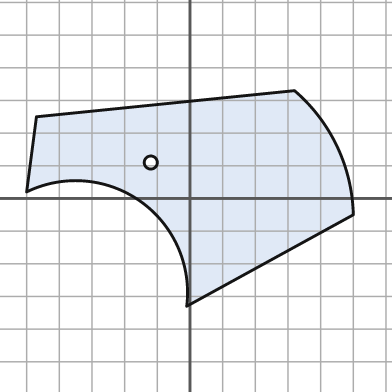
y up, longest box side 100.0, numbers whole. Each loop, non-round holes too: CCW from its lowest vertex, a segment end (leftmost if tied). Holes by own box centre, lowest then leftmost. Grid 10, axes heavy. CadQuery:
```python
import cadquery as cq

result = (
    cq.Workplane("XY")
    .moveTo(-1.0, -33.0)
    .lineTo(50.0, -5.0)
    .threePointArc((45.0, 16.0), (32.0, 33.0))
    .lineTo(-47.0, 25.0)
    .lineTo(-50.0, 2.0)
    .threePointArc((-15.0, -1.0), (-1.0, -33.0))
    .close()
    .moveTo(-12.0, 11.0)
    .circle(2.0)
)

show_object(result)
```